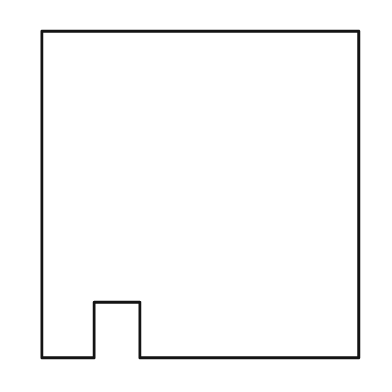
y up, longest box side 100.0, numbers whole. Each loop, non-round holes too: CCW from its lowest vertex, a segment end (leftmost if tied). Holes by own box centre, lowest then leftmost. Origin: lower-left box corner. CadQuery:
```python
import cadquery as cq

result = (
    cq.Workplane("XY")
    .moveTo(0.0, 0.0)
    .lineTo(16.0, 0.0)
    .lineTo(16.0, 17.0)
    .lineTo(30.0, 17.0)
    .lineTo(30.0, 0.0)
    .lineTo(97.0, 0.0)
    .lineTo(97.0, 100.0)
    .lineTo(0.0, 100.0)
    .close()
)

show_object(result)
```